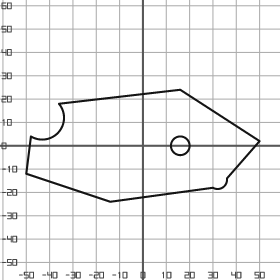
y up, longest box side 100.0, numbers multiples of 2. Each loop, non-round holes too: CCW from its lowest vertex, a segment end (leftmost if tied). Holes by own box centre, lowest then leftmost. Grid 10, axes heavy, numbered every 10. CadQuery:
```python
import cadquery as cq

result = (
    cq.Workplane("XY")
    .moveTo(-14.0, -24.0)
    .lineTo(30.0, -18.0)
    .threePointArc((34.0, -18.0), (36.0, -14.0))
    .lineTo(50.0, 2.0)
    .lineTo(16.0, 24.0)
    .lineTo(-36.0, 18.0)
    .threePointArc((-36.0, 6.0), (-48.0, 4.0))
    .lineTo(-50.0, -12.0)
    .close()
    .moveTo(16.0, 0.0)
    .circle(4.0)
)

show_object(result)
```